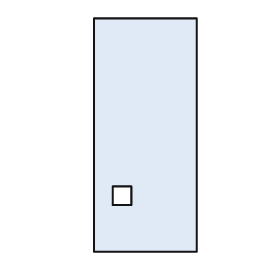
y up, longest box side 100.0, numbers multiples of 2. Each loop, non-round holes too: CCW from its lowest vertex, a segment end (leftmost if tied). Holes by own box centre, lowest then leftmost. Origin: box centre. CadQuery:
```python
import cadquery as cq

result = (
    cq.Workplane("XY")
    .moveTo(-22.0, -50.0)
    .lineTo(22.0, -50.0)
    .lineTo(22.0, 50.0)
    .lineTo(-22.0, 50.0)
    .close()
    .moveTo(-14.0, -30.0)
    .lineTo(-6.0, -30.0)
    .lineTo(-6.0, -22.0)
    .lineTo(-14.0, -22.0)
    .close()
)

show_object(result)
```